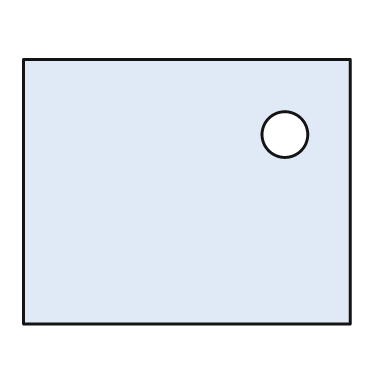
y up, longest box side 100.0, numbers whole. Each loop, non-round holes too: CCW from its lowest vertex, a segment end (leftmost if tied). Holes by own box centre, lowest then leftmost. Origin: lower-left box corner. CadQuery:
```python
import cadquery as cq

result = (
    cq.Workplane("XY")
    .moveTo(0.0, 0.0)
    .lineTo(100.0, 0.0)
    .lineTo(100.0, 81.0)
    .lineTo(0.0, 81.0)
    .close()
    .moveTo(80.0, 58.0)
    .circle(7.0)
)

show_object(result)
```